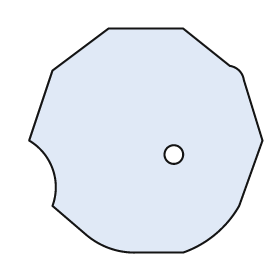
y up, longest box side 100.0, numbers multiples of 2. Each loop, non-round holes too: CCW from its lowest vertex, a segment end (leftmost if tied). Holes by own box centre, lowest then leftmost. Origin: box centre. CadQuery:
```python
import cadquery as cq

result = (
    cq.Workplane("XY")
    .moveTo(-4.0, -48.0)
    .lineTo(16.0, -48.0)
    .threePointArc((30.0, -40.0), (40.0, -28.0))
    .lineTo(50.0, 0.0)
    .lineTo(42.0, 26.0)
    .threePointArc((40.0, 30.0), (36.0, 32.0))
    .lineTo(16.0, 48.0)
    .lineTo(-16.0, 48.0)
    .lineTo(-40.0, 30.0)
    .lineTo(-50.0, 0.0)
    .threePointArc((-40.0, -12.0), (-40.0, -28.0))
    .lineTo(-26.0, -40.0)
    .threePointArc((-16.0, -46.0), (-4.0, -48.0))
    .close()
    .moveTo(12.0, -6.0)
    .circle(4.0)
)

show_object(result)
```